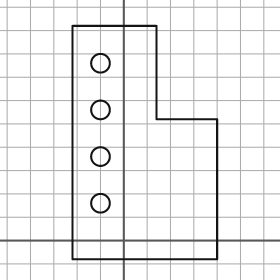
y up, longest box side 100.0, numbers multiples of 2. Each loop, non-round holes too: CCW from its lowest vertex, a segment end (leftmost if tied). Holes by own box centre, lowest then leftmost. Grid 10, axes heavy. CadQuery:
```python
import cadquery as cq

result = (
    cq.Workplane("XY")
    .moveTo(-22.0, -8.0)
    .lineTo(40.0, -8.0)
    .lineTo(40.0, 52.0)
    .lineTo(14.0, 52.0)
    .lineTo(14.0, 92.0)
    .lineTo(-22.0, 92.0)
    .close()
    .moveTo(-10.0, 16.0)
    .circle(4.0)
    .moveTo(-10.0, 36.0)
    .circle(4.0)
    .moveTo(-10.0, 56.0)
    .circle(4.0)
    .moveTo(-10.0, 76.0)
    .circle(4.0)
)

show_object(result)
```